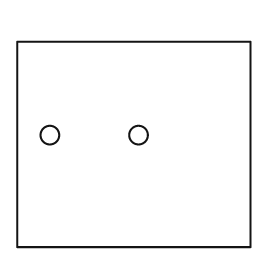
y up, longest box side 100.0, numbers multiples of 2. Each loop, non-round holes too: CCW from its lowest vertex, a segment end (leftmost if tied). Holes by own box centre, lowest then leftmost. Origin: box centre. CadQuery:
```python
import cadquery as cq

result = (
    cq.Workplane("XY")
    .moveTo(-50.0, -44.0)
    .lineTo(50.0, -44.0)
    .lineTo(50.0, 44.0)
    .lineTo(-50.0, 44.0)
    .close()
    .moveTo(-36.0, 4.0)
    .circle(4.0)
    .moveTo(2.0, 4.0)
    .circle(4.0)
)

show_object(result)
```